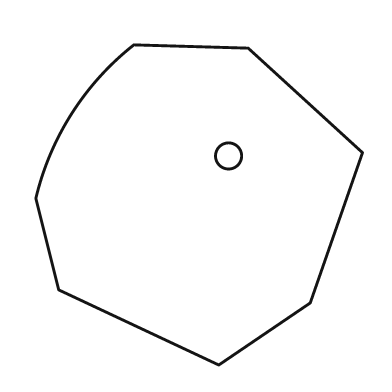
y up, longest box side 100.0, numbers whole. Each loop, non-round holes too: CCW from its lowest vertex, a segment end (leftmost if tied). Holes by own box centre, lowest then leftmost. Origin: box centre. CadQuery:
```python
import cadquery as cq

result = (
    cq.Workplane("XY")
    .moveTo(6.0, -49.0)
    .lineTo(34.0, -30.0)
    .lineTo(50.0, 16.0)
    .lineTo(15.0, 48.0)
    .lineTo(-20.0, 49.0)
    .threePointArc((-39.0, 28.0), (-50.0, 2.0))
    .lineTo(-43.0, -26.0)
    .close()
    .moveTo(9.0, 15.0)
    .circle(4.0)
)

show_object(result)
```